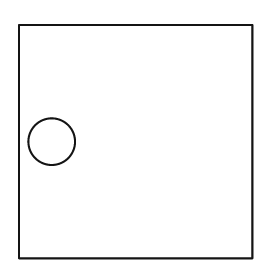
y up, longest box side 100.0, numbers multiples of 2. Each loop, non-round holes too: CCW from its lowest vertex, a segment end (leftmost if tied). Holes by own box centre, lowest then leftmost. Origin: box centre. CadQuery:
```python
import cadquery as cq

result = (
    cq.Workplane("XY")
    .moveTo(-50.0, -50.0)
    .lineTo(50.0, -50.0)
    .lineTo(50.0, 50.0)
    .lineTo(-50.0, 50.0)
    .close()
    .moveTo(-36.0, 0.0)
    .circle(10.0)
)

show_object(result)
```